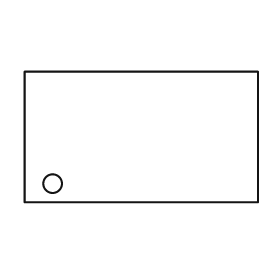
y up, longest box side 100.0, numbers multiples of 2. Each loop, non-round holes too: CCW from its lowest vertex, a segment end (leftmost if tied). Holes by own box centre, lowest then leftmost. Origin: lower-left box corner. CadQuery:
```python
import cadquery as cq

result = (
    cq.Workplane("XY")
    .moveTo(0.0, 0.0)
    .lineTo(100.0, 0.0)
    .lineTo(100.0, 56.0)
    .lineTo(0.0, 56.0)
    .close()
    .moveTo(12.0, 8.0)
    .circle(4.0)
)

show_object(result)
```